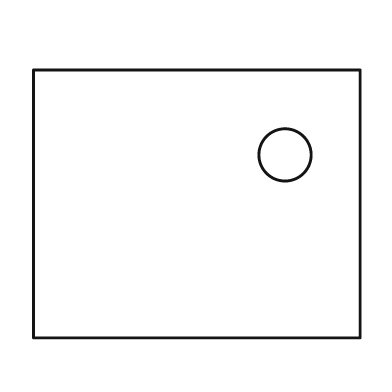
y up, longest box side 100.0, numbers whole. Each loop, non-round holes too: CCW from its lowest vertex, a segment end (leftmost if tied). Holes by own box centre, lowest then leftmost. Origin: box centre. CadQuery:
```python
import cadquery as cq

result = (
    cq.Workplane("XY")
    .moveTo(-50.0, -41.0)
    .lineTo(50.0, -41.0)
    .lineTo(50.0, 41.0)
    .lineTo(-50.0, 41.0)
    .close()
    .moveTo(27.0, 15.0)
    .circle(8.0)
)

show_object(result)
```